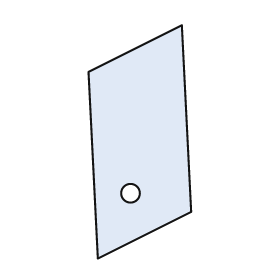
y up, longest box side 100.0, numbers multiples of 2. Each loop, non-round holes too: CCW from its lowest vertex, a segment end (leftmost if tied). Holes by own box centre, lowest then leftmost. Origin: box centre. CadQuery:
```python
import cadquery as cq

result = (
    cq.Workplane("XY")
    .moveTo(-18.0, -50.0)
    .lineTo(22.0, -30.0)
    .lineTo(18.0, 50.0)
    .lineTo(-22.0, 30.0)
    .close()
    .moveTo(-4.0, -22.0)
    .circle(4.0)
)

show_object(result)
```